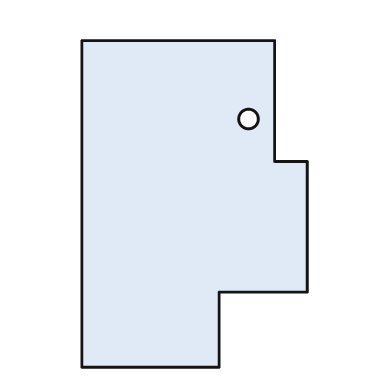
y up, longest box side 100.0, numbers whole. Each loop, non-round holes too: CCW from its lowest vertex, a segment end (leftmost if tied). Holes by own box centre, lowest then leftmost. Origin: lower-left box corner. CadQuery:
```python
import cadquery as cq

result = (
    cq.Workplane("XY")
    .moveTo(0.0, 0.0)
    .lineTo(42.0, 0.0)
    .lineTo(42.0, 23.0)
    .lineTo(69.0, 23.0)
    .lineTo(69.0, 63.0)
    .lineTo(59.0, 63.0)
    .lineTo(59.0, 100.0)
    .lineTo(0.0, 100.0)
    .close()
    .moveTo(51.0, 76.0)
    .circle(3.0)
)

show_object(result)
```